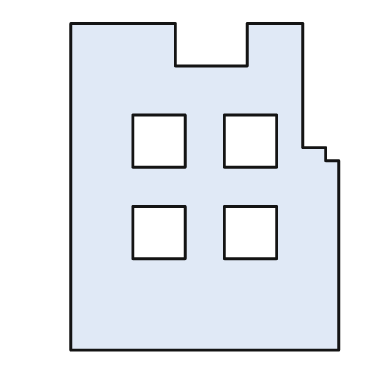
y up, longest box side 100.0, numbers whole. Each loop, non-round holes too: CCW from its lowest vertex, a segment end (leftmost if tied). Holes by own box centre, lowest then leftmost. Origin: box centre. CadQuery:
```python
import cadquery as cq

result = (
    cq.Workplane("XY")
    .moveTo(-41.0, -50.0)
    .lineTo(41.0, -50.0)
    .lineTo(41.0, 8.0)
    .lineTo(37.0, 8.0)
    .lineTo(37.0, 12.0)
    .lineTo(30.0, 12.0)
    .lineTo(30.0, 50.0)
    .lineTo(13.0, 50.0)
    .lineTo(13.0, 37.0)
    .lineTo(-9.0, 37.0)
    .lineTo(-9.0, 50.0)
    .lineTo(-41.0, 50.0)
    .close()
    .moveTo(-22.0, -22.0)
    .lineTo(-6.0, -22.0)
    .lineTo(-6.0, -6.0)
    .lineTo(-22.0, -6.0)
    .close()
    .moveTo(6.0, -22.0)
    .lineTo(22.0, -22.0)
    .lineTo(22.0, -6.0)
    .lineTo(6.0, -6.0)
    .close()
    .moveTo(-22.0, 6.0)
    .lineTo(-6.0, 6.0)
    .lineTo(-6.0, 22.0)
    .lineTo(-22.0, 22.0)
    .close()
    .moveTo(6.0, 6.0)
    .lineTo(22.0, 6.0)
    .lineTo(22.0, 22.0)
    .lineTo(6.0, 22.0)
    .close()
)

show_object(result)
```